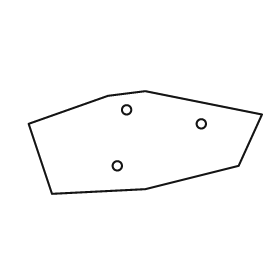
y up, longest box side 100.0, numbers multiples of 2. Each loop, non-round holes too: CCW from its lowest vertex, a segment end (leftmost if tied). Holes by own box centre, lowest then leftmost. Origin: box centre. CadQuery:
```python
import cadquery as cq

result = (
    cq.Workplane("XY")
    .moveTo(-40.0, -22.0)
    .lineTo(0.0, -20.0)
    .lineTo(40.0, -10.0)
    .lineTo(50.0, 12.0)
    .lineTo(0.0, 22.0)
    .lineTo(-16.0, 20.0)
    .lineTo(-50.0, 8.0)
    .close()
    .moveTo(-12.0, -10.0)
    .circle(2.0)
    .moveTo(24.0, 8.0)
    .circle(2.0)
    .moveTo(-8.0, 14.0)
    .circle(2.0)
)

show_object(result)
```